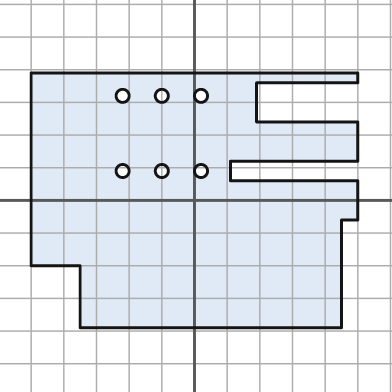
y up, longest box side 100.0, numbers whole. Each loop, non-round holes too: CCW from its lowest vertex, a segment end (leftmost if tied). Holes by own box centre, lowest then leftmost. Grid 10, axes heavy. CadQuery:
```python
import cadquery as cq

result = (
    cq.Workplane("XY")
    .moveTo(-35.0, -39.0)
    .lineTo(45.0, -39.0)
    .lineTo(45.0, -6.0)
    .lineTo(50.0, -6.0)
    .lineTo(50.0, 6.0)
    .lineTo(11.0, 6.0)
    .lineTo(11.0, 12.0)
    .lineTo(50.0, 12.0)
    .lineTo(50.0, 24.0)
    .lineTo(19.0, 24.0)
    .lineTo(19.0, 36.0)
    .lineTo(50.0, 36.0)
    .lineTo(50.0, 39.0)
    .lineTo(-50.0, 39.0)
    .lineTo(-50.0, -20.0)
    .lineTo(-35.0, -20.0)
    .close()
    .moveTo(-22.0, 9.0)
    .circle(2.0)
    .moveTo(-10.0, 9.0)
    .circle(2.0)
    .moveTo(2.0, 9.0)
    .circle(2.0)
    .moveTo(-22.0, 32.0)
    .circle(2.0)
    .moveTo(-10.0, 32.0)
    .circle(2.0)
    .moveTo(2.0, 32.0)
    .circle(2.0)
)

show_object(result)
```